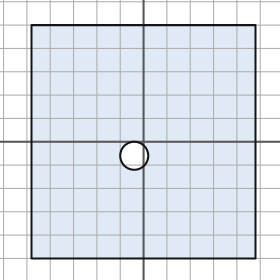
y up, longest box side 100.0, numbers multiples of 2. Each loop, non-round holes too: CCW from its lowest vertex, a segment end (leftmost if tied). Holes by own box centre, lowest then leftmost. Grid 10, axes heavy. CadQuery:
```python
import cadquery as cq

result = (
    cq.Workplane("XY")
    .moveTo(-48.0, -50.0)
    .lineTo(48.0, -50.0)
    .lineTo(48.0, 50.0)
    .lineTo(-48.0, 50.0)
    .close()
    .moveTo(-4.0, -6.0)
    .circle(6.0)
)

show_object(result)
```